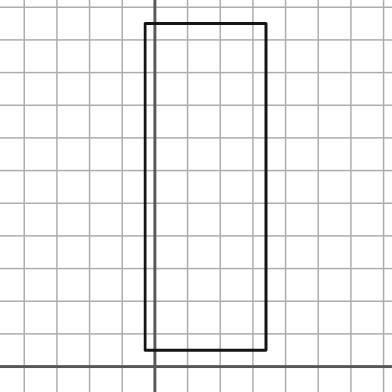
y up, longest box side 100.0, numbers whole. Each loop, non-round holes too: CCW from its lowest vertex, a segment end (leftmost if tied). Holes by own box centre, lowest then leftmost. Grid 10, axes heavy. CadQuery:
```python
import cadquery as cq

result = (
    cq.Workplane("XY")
    .moveTo(-3.0, 5.0)
    .lineTo(34.0, 5.0)
    .lineTo(34.0, 105.0)
    .lineTo(-3.0, 105.0)
    .close()
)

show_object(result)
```